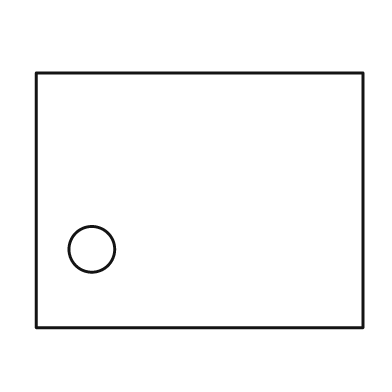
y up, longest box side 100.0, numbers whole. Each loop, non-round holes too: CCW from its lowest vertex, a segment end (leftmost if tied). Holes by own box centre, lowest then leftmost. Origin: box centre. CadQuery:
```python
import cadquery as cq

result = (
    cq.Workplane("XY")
    .moveTo(-50.0, -39.0)
    .lineTo(50.0, -39.0)
    .lineTo(50.0, 39.0)
    .lineTo(-50.0, 39.0)
    .close()
    .moveTo(-33.0, -15.0)
    .circle(7.0)
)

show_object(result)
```